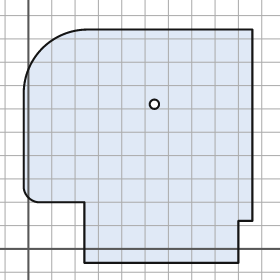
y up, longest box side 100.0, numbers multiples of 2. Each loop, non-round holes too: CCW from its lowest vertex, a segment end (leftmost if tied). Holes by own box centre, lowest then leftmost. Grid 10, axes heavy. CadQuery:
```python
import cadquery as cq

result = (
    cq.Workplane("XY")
    .moveTo(24.0, -6.0)
    .lineTo(90.0, -6.0)
    .lineTo(90.0, 12.0)
    .lineTo(96.0, 12.0)
    .lineTo(96.0, 94.0)
    .lineTo(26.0, 94.0)
    .threePointArc((6.0, 86.0), (-2.0, 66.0))
    .lineTo(-2.0, 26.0)
    .threePointArc((0.0, 22.0), (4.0, 20.0))
    .lineTo(24.0, 20.0)
    .close()
    .moveTo(54.0, 62.0)
    .circle(2.0)
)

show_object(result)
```